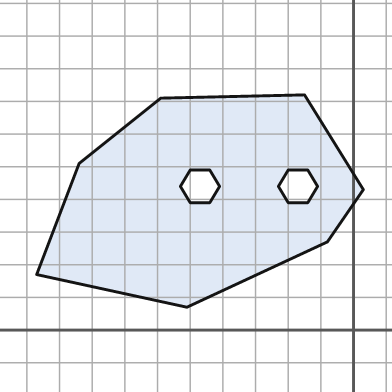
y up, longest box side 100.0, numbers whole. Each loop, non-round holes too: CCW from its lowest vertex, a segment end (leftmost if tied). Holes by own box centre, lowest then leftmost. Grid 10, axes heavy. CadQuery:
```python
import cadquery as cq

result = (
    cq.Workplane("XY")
    .moveTo(-51.0, 7.0)
    .lineTo(-8.0, 27.0)
    .lineTo(3.0, 43.0)
    .lineTo(-15.0, 72.0)
    .lineTo(-59.0, 71.0)
    .lineTo(-84.0, 51.0)
    .lineTo(-97.0, 17.0)
    .close()
    .moveTo(-50.0, 39.0)
    .lineTo(-44.0, 39.0)
    .lineTo(-41.0, 44.0)
    .lineTo(-44.0, 49.0)
    .lineTo(-50.0, 49.0)
    .lineTo(-53.0, 44.0)
    .close()
    .moveTo(-20.0, 39.0)
    .lineTo(-14.0, 39.0)
    .lineTo(-11.0, 44.0)
    .lineTo(-14.0, 49.0)
    .lineTo(-20.0, 49.0)
    .lineTo(-23.0, 44.0)
    .close()
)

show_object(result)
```